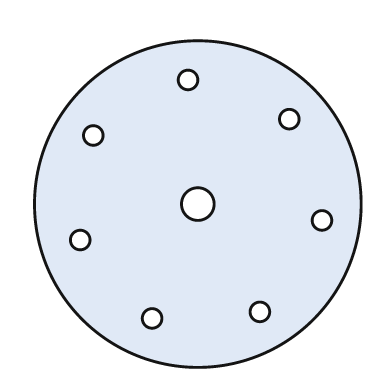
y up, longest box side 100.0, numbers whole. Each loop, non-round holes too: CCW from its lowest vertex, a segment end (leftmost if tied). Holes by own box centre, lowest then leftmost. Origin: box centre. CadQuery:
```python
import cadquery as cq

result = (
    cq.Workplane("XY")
    .moveTo(0.0, 0.0)
    .circle(50.0)
    .moveTo(-14.0, -35.0)
    .circle(3.0)
    .moveTo(19.0, -33.0)
    .circle(3.0)
    .moveTo(-36.0, -11.0)
    .circle(3.0)
    .moveTo(38.0, -5.0)
    .circle(3.0)
    .moveTo(0.0, 0.0)
    .circle(5.0)
    .moveTo(-32.0, 21.0)
    .circle(3.0)
    .moveTo(28.0, 26.0)
    .circle(3.0)
    .moveTo(-3.0, 38.0)
    .circle(3.0)
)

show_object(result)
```